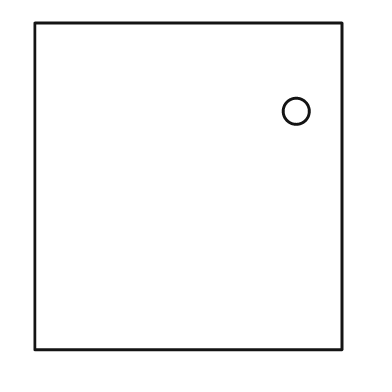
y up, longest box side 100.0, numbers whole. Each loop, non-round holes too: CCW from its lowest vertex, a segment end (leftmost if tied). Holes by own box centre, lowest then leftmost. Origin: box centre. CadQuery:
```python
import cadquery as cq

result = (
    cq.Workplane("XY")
    .moveTo(-47.0, -50.0)
    .lineTo(47.0, -50.0)
    .lineTo(47.0, 50.0)
    .lineTo(-47.0, 50.0)
    .close()
    .moveTo(33.0, 23.0)
    .circle(4.0)
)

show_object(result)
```